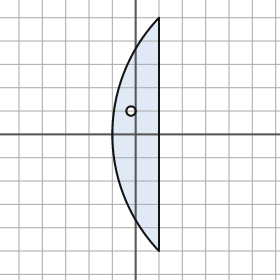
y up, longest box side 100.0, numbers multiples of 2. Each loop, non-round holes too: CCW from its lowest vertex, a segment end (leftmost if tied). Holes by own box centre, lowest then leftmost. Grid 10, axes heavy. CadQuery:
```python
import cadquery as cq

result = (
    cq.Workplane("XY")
    .moveTo(10.0, -50.0)
    .lineTo(10.0, 50.0)
    .threePointArc((-10.0, 0.0), (10.0, -50.0))
    .close()
    .moveTo(-2.0, 10.0)
    .circle(2.0)
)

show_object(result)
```